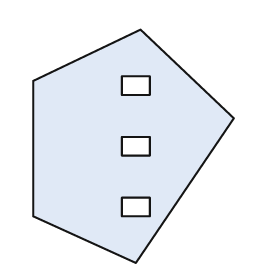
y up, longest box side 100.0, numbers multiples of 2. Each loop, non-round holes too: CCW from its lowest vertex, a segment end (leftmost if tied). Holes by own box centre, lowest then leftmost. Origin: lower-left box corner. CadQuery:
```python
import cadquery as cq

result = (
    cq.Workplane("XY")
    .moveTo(44.0, 0.0)
    .lineTo(86.0, 62.0)
    .lineTo(46.0, 100.0)
    .lineTo(0.0, 78.0)
    .lineTo(0.0, 20.0)
    .close()
    .moveTo(38.0, 20.0)
    .lineTo(50.0, 20.0)
    .lineTo(50.0, 28.0)
    .lineTo(38.0, 28.0)
    .close()
    .moveTo(38.0, 46.0)
    .lineTo(50.0, 46.0)
    .lineTo(50.0, 54.0)
    .lineTo(38.0, 54.0)
    .close()
    .moveTo(38.0, 72.0)
    .lineTo(50.0, 72.0)
    .lineTo(50.0, 80.0)
    .lineTo(38.0, 80.0)
    .close()
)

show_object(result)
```